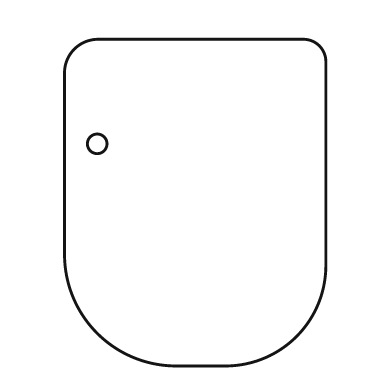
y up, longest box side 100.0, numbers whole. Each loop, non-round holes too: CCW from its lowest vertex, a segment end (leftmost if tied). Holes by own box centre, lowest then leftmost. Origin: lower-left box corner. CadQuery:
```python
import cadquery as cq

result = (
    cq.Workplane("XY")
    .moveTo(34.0, 0.0)
    .lineTo(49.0, 0.0)
    .threePointArc((71.0, 9.0), (80.0, 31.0))
    .lineTo(80.0, 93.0)
    .threePointArc((78.0, 98.0), (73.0, 100.0))
    .lineTo(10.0, 100.0)
    .threePointArc((3.0, 97.0), (0.0, 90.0))
    .lineTo(0.0, 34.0)
    .threePointArc((10.0, 10.0), (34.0, 0.0))
    .close()
    .moveTo(10.0, 68.0)
    .circle(3.0)
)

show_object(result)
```